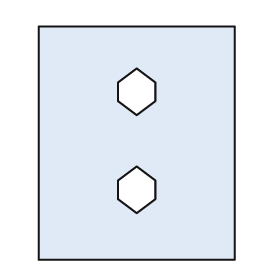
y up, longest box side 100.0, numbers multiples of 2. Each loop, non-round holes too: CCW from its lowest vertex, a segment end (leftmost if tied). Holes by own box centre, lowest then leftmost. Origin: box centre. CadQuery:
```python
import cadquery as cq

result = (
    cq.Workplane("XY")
    .moveTo(-42.0, -50.0)
    .lineTo(42.0, -50.0)
    .lineTo(42.0, 50.0)
    .lineTo(-42.0, 50.0)
    .close()
    .moveTo(0.0, -30.0)
    .lineTo(8.0, -24.0)
    .lineTo(8.0, -16.0)
    .lineTo(0.0, -10.0)
    .lineTo(-8.0, -16.0)
    .lineTo(-8.0, -24.0)
    .close()
    .moveTo(0.0, 12.0)
    .lineTo(8.0, 18.0)
    .lineTo(8.0, 26.0)
    .lineTo(0.0, 32.0)
    .lineTo(-8.0, 26.0)
    .lineTo(-8.0, 18.0)
    .close()
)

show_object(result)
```